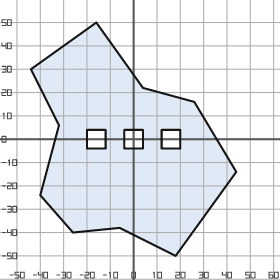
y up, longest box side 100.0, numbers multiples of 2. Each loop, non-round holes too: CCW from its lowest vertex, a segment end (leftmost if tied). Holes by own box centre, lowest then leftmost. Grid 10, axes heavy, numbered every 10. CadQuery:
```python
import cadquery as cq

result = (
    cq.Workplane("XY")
    .moveTo(18.0, -50.0)
    .lineTo(44.0, -14.0)
    .lineTo(26.0, 16.0)
    .lineTo(4.0, 22.0)
    .lineTo(-16.0, 50.0)
    .lineTo(-44.0, 30.0)
    .lineTo(-32.0, 6.0)
    .lineTo(-40.0, -24.0)
    .lineTo(-26.0, -40.0)
    .lineTo(-6.0, -38.0)
    .close()
    .moveTo(-20.0, -4.0)
    .lineTo(-12.0, -4.0)
    .lineTo(-12.0, 4.0)
    .lineTo(-20.0, 4.0)
    .close()
    .moveTo(-4.0, -4.0)
    .lineTo(4.0, -4.0)
    .lineTo(4.0, 4.0)
    .lineTo(-4.0, 4.0)
    .close()
    .moveTo(12.0, -4.0)
    .lineTo(20.0, -4.0)
    .lineTo(20.0, 4.0)
    .lineTo(12.0, 4.0)
    .close()
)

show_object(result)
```